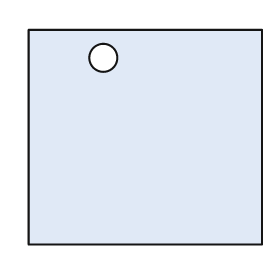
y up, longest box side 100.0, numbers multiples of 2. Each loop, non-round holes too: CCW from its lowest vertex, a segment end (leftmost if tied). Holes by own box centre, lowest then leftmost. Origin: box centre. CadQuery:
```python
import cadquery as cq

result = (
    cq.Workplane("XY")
    .moveTo(-50.0, -46.0)
    .lineTo(50.0, -46.0)
    .lineTo(50.0, 46.0)
    .lineTo(-50.0, 46.0)
    .close()
    .moveTo(-18.0, 34.0)
    .circle(6.0)
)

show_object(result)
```